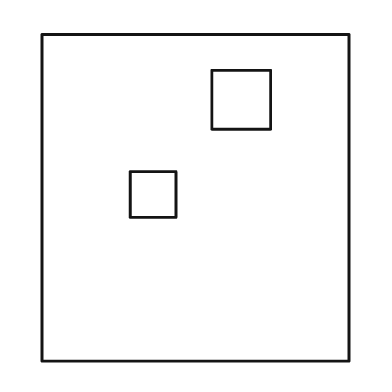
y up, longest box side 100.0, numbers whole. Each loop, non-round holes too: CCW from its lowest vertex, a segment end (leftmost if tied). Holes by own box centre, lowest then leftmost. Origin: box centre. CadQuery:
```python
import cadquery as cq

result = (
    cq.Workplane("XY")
    .moveTo(-47.0, -50.0)
    .lineTo(47.0, -50.0)
    .lineTo(47.0, 50.0)
    .lineTo(-47.0, 50.0)
    .close()
    .moveTo(-20.0, -6.0)
    .lineTo(-6.0, -6.0)
    .lineTo(-6.0, 8.0)
    .lineTo(-20.0, 8.0)
    .close()
    .moveTo(5.0, 21.0)
    .lineTo(23.0, 21.0)
    .lineTo(23.0, 39.0)
    .lineTo(5.0, 39.0)
    .close()
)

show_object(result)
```